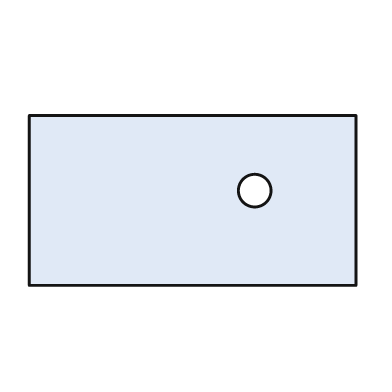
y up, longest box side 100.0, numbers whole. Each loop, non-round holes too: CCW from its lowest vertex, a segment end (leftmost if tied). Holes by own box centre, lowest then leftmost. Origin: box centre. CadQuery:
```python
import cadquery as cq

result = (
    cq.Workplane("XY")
    .moveTo(-50.0, -26.0)
    .lineTo(50.0, -26.0)
    .lineTo(50.0, 26.0)
    .lineTo(-50.0, 26.0)
    .close()
    .moveTo(19.0, 3.0)
    .circle(5.0)
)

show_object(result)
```